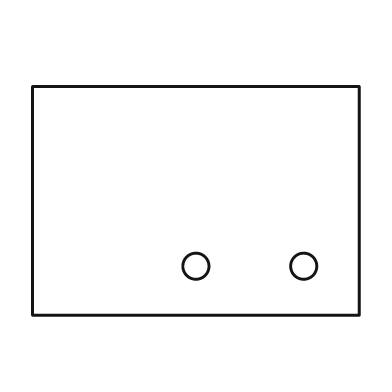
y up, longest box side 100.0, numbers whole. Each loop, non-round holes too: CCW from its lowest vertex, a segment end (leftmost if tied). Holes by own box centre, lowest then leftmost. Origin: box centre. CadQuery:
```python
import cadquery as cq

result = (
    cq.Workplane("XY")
    .moveTo(-50.0, -35.0)
    .lineTo(50.0, -35.0)
    .lineTo(50.0, 35.0)
    .lineTo(-50.0, 35.0)
    .close()
    .moveTo(0.0, -20.0)
    .circle(4.0)
    .moveTo(33.0, -20.0)
    .circle(4.0)
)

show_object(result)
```